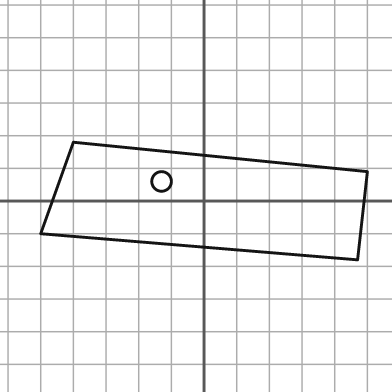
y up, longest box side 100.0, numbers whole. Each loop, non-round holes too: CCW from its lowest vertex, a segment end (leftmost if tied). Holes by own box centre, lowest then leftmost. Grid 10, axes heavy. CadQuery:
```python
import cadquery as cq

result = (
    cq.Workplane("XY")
    .moveTo(47.0, -18.0)
    .lineTo(50.0, 9.0)
    .lineTo(-40.0, 18.0)
    .lineTo(-50.0, -10.0)
    .close()
    .moveTo(-13.0, 6.0)
    .circle(3.0)
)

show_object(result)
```